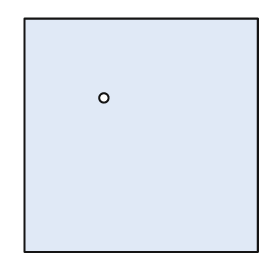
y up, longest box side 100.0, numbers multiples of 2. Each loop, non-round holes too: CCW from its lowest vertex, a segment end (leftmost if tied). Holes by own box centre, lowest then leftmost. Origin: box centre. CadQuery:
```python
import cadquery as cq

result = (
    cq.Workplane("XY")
    .moveTo(-50.0, -50.0)
    .lineTo(50.0, -50.0)
    .lineTo(50.0, 50.0)
    .lineTo(-50.0, 50.0)
    .close()
    .moveTo(-16.0, 16.0)
    .circle(2.0)
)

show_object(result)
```